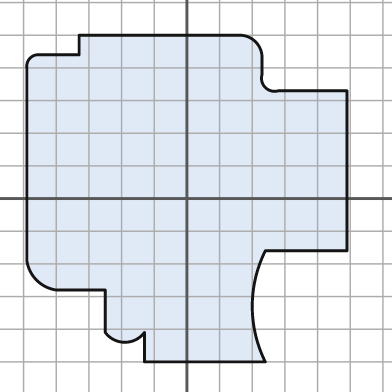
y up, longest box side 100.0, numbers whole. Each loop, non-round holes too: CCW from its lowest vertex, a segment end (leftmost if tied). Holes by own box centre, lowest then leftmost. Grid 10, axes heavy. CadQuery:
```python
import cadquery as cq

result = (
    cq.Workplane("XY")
    .moveTo(-13.0, -50.0)
    .lineTo(24.0, -50.0)
    .threePointArc((20.0, -33.0), (24.0, -16.0))
    .lineTo(49.0, -16.0)
    .lineTo(49.0, 33.0)
    .lineTo(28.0, 33.0)
    .threePointArc((24.0, 34.0), (23.0, 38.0))
    .lineTo(23.0, 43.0)
    .threePointArc((21.0, 48.0), (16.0, 50.0))
    .lineTo(-33.0, 50.0)
    .lineTo(-33.0, 44.0)
    .lineTo(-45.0, 44.0)
    .threePointArc((-48.0, 43.0), (-49.0, 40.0))
    .lineTo(-49.0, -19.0)
    .threePointArc((-46.0, -25.0), (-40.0, -28.0))
    .lineTo(-25.0, -28.0)
    .lineTo(-25.0, -41.0)
    .threePointArc((-19.0, -44.0), (-13.0, -41.0))
    .close()
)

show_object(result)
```